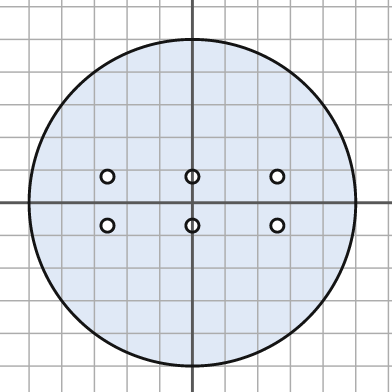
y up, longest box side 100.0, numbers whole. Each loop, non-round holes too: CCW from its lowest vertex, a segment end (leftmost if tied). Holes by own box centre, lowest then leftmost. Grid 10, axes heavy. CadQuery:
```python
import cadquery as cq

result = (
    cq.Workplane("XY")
    .moveTo(0.0, 0.0)
    .circle(50.0)
    .moveTo(-26.0, -7.0)
    .circle(2.0)
    .moveTo(0.0, -7.0)
    .circle(2.0)
    .moveTo(26.0, -7.0)
    .circle(2.0)
    .moveTo(-26.0, 8.0)
    .circle(2.0)
    .moveTo(0.0, 8.0)
    .circle(2.0)
    .moveTo(26.0, 8.0)
    .circle(2.0)
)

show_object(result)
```